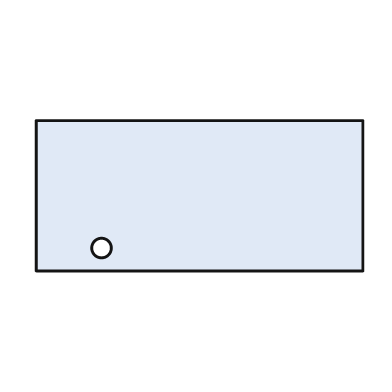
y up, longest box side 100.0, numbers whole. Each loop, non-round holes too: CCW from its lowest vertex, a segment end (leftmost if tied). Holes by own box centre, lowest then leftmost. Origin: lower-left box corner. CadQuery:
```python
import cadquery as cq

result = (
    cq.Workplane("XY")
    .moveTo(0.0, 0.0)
    .lineTo(100.0, 0.0)
    .lineTo(100.0, 46.0)
    .lineTo(0.0, 46.0)
    .close()
    .moveTo(20.0, 7.0)
    .circle(3.0)
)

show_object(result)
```